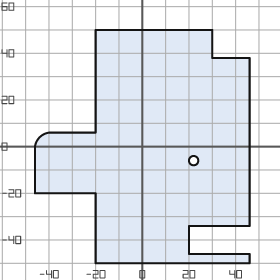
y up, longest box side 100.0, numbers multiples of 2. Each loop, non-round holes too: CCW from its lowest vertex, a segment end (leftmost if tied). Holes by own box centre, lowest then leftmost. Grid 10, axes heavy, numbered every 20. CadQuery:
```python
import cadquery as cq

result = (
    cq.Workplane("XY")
    .moveTo(-20.0, -50.0)
    .lineTo(46.0, -50.0)
    .lineTo(46.0, -46.0)
    .lineTo(20.0, -46.0)
    .lineTo(20.0, -34.0)
    .lineTo(46.0, -34.0)
    .lineTo(46.0, 38.0)
    .lineTo(30.0, 38.0)
    .lineTo(30.0, 50.0)
    .lineTo(-20.0, 50.0)
    .lineTo(-20.0, 6.0)
    .lineTo(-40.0, 6.0)
    .threePointArc((-44.0, 4.0), (-46.0, 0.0))
    .lineTo(-46.0, -20.0)
    .lineTo(-20.0, -20.0)
    .close()
    .moveTo(22.0, -6.0)
    .circle(2.0)
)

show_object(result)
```